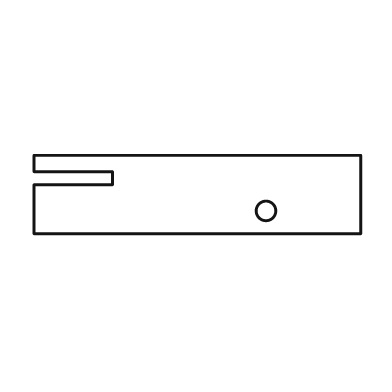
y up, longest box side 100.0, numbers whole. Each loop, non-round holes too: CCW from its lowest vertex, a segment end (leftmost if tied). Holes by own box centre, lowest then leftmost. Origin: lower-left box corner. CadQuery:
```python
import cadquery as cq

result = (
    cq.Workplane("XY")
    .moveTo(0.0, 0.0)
    .lineTo(100.0, 0.0)
    .lineTo(100.0, 24.0)
    .lineTo(0.0, 24.0)
    .lineTo(0.0, 19.0)
    .lineTo(24.0, 19.0)
    .lineTo(24.0, 15.0)
    .lineTo(0.0, 15.0)
    .close()
    .moveTo(71.0, 7.0)
    .circle(3.0)
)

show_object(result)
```